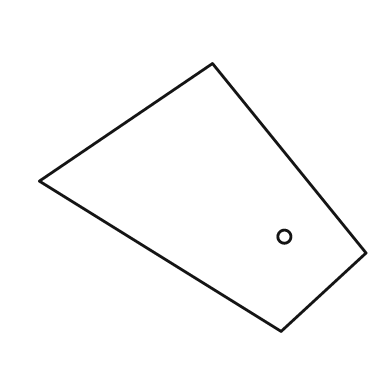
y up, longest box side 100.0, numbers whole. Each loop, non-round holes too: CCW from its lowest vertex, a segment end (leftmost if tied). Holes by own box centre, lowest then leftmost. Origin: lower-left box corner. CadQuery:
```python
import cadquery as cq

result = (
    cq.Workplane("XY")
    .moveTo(74.0, 0.0)
    .lineTo(100.0, 24.0)
    .lineTo(53.0, 82.0)
    .lineTo(0.0, 46.0)
    .close()
    .moveTo(75.0, 29.0)
    .circle(2.0)
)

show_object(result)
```